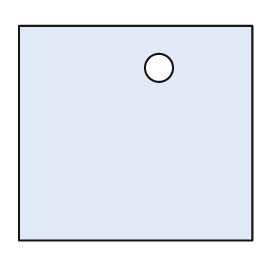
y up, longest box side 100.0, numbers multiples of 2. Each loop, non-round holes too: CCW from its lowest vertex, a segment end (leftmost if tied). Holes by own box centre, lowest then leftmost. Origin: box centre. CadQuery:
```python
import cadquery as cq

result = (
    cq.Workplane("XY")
    .moveTo(-50.0, -46.0)
    .lineTo(50.0, -46.0)
    .lineTo(50.0, 46.0)
    .lineTo(-50.0, 46.0)
    .close()
    .moveTo(10.0, 28.0)
    .circle(6.0)
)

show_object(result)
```